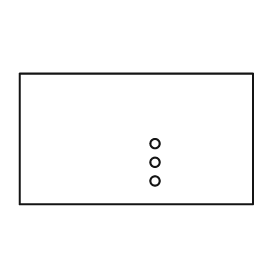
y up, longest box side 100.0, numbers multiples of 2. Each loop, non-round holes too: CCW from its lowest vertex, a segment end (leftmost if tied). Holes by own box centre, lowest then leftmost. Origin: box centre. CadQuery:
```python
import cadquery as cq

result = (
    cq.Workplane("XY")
    .moveTo(-50.0, -28.0)
    .lineTo(50.0, -28.0)
    .lineTo(50.0, 28.0)
    .lineTo(-50.0, 28.0)
    .close()
    .moveTo(8.0, -18.0)
    .circle(2.0)
    .moveTo(8.0, -10.0)
    .circle(2.0)
    .moveTo(8.0, -2.0)
    .circle(2.0)
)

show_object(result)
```